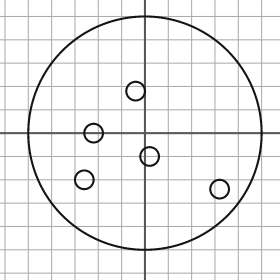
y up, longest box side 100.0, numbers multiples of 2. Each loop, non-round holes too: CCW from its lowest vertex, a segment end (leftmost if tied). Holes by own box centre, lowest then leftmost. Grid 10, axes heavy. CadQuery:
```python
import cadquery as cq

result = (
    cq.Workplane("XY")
    .moveTo(0.0, 0.0)
    .circle(50.0)
    .moveTo(32.0, -24.0)
    .circle(4.0)
    .moveTo(-26.0, -20.0)
    .circle(4.0)
    .moveTo(2.0, -10.0)
    .circle(4.0)
    .moveTo(-22.0, 0.0)
    .circle(4.0)
    .moveTo(-4.0, 18.0)
    .circle(4.0)
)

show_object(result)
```